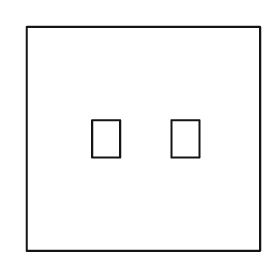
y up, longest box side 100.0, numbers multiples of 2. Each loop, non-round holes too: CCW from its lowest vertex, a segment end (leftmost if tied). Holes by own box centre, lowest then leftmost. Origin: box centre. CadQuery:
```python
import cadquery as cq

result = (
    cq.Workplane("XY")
    .moveTo(-50.0, -48.0)
    .lineTo(50.0, -48.0)
    .lineTo(50.0, 48.0)
    .lineTo(-50.0, 48.0)
    .close()
    .moveTo(-22.0, -8.0)
    .lineTo(-10.0, -8.0)
    .lineTo(-10.0, 8.0)
    .lineTo(-22.0, 8.0)
    .close()
    .moveTo(12.0, -8.0)
    .lineTo(24.0, -8.0)
    .lineTo(24.0, 8.0)
    .lineTo(12.0, 8.0)
    .close()
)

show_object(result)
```